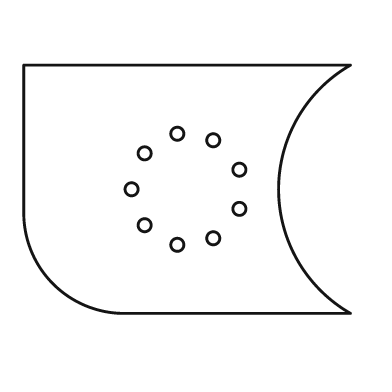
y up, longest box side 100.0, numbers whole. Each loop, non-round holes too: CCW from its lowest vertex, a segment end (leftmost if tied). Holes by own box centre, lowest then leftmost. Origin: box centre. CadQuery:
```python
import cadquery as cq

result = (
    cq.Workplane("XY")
    .moveTo(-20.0, -38.0)
    .lineTo(50.0, -38.0)
    .threePointArc((28.0, 0.0), (50.0, 38.0))
    .lineTo(-50.0, 38.0)
    .lineTo(-50.0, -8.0)
    .threePointArc((-41.0, -29.0), (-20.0, -38.0))
    .close()
    .moveTo(-3.0, -17.0)
    .circle(2.0)
    .moveTo(8.0, -15.0)
    .circle(2.0)
    .moveTo(-13.0, -11.0)
    .circle(2.0)
    .moveTo(16.0, -6.0)
    .circle(2.0)
    .moveTo(-17.0, 0.0)
    .circle(2.0)
    .moveTo(16.0, 6.0)
    .circle(2.0)
    .moveTo(-13.0, 11.0)
    .circle(2.0)
    .moveTo(8.0, 15.0)
    .circle(2.0)
    .moveTo(-3.0, 17.0)
    .circle(2.0)
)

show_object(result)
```